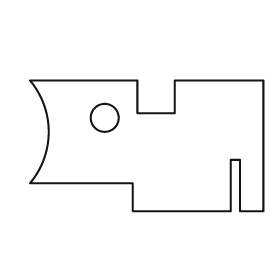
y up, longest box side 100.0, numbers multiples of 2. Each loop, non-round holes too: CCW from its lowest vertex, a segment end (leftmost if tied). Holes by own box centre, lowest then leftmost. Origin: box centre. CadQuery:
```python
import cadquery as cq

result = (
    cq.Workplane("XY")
    .moveTo(-6.0, -28.0)
    .lineTo(36.0, -28.0)
    .lineTo(36.0, -6.0)
    .lineTo(40.0, -6.0)
    .lineTo(40.0, -28.0)
    .lineTo(50.0, -28.0)
    .lineTo(50.0, 28.0)
    .lineTo(12.0, 28.0)
    .lineTo(12.0, 14.0)
    .lineTo(-4.0, 14.0)
    .lineTo(-4.0, 28.0)
    .lineTo(-50.0, 28.0)
    .threePointArc((-42.0, 6.0), (-50.0, -16.0))
    .lineTo(-6.0, -16.0)
    .close()
    .moveTo(-18.0, 12.0)
    .circle(6.0)
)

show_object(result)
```